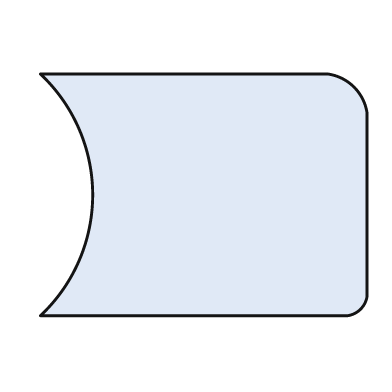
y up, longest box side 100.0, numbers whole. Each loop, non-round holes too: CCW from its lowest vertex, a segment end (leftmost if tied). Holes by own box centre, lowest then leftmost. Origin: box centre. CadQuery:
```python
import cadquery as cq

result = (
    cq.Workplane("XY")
    .moveTo(-50.0, -37.0)
    .lineTo(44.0, -37.0)
    .threePointArc((48.0, -35.0), (50.0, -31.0))
    .lineTo(50.0, 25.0)
    .threePointArc((46.0, 33.0), (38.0, 37.0))
    .lineTo(-50.0, 37.0)
    .threePointArc((-34.0, 0.0), (-50.0, -37.0))
    .close()
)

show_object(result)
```